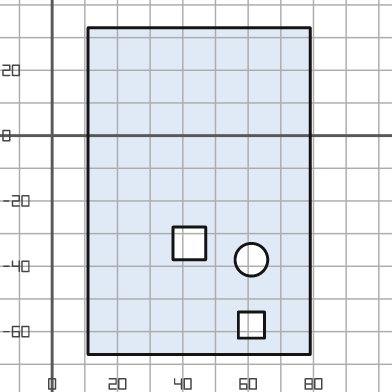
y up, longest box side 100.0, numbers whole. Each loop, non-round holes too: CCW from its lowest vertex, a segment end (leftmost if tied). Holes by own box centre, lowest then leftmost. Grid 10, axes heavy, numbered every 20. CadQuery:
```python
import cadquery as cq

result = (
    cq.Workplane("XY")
    .moveTo(11.0, -67.0)
    .lineTo(79.0, -67.0)
    .lineTo(79.0, 33.0)
    .lineTo(11.0, 33.0)
    .close()
    .moveTo(57.0, -62.0)
    .lineTo(65.0, -62.0)
    .lineTo(65.0, -54.0)
    .lineTo(57.0, -54.0)
    .close()
    .moveTo(61.0, -38.0)
    .circle(5.0)
    .moveTo(37.0, -38.0)
    .lineTo(47.0, -38.0)
    .lineTo(47.0, -28.0)
    .lineTo(37.0, -28.0)
    .close()
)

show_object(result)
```